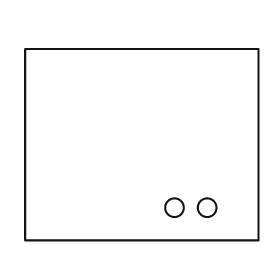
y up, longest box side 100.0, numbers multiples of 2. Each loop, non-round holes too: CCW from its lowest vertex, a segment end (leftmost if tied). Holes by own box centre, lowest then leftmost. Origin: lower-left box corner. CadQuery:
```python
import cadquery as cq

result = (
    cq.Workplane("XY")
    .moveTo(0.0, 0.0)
    .lineTo(100.0, 0.0)
    .lineTo(100.0, 82.0)
    .lineTo(0.0, 82.0)
    .close()
    .moveTo(64.0, 14.0)
    .circle(4.0)
    .moveTo(78.0, 14.0)
    .circle(4.0)
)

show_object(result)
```